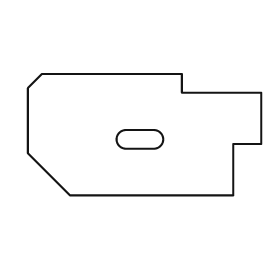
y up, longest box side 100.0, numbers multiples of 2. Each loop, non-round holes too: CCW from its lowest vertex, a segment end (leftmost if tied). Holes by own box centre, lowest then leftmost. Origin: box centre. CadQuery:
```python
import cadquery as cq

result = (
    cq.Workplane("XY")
    .moveTo(-32.0, -26.0)
    .lineTo(38.0, -26.0)
    .lineTo(38.0, -4.0)
    .lineTo(50.0, -4.0)
    .lineTo(50.0, 18.0)
    .lineTo(16.0, 18.0)
    .lineTo(16.0, 26.0)
    .lineTo(-44.0, 26.0)
    .lineTo(-50.0, 20.0)
    .lineTo(-50.0, -8.0)
    .close()
    .moveTo(-8.0, -6.0)
    .lineTo(4.0, -6.0)
    .threePointArc((8.0, -2.0), (4.0, 2.0))
    .lineTo(-8.0, 2.0)
    .threePointArc((-12.0, -2.0), (-8.0, -6.0))
    .close()
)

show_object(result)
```